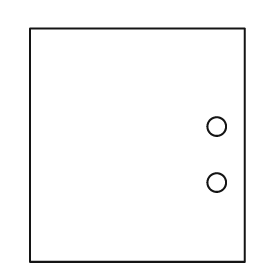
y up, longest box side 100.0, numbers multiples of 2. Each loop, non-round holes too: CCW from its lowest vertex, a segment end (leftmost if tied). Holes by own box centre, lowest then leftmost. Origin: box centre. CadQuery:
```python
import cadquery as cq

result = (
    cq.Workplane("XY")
    .moveTo(-46.0, -50.0)
    .lineTo(46.0, -50.0)
    .lineTo(46.0, 50.0)
    .lineTo(-46.0, 50.0)
    .close()
    .moveTo(34.0, -16.0)
    .circle(4.0)
    .moveTo(34.0, 8.0)
    .circle(4.0)
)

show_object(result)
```